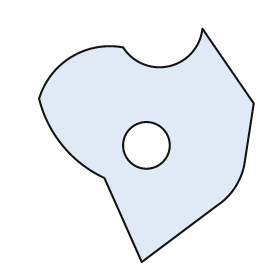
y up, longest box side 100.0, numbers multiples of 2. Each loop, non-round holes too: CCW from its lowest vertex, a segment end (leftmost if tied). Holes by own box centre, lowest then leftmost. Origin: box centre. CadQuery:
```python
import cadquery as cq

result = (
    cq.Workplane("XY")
    .moveTo(-2.0, -50.0)
    .lineTo(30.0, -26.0)
    .threePointArc((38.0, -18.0), (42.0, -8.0))
    .lineTo(46.0, 18.0)
    .lineTo(24.0, 50.0)
    .threePointArc((10.0, 34.0), (-10.0, 42.0))
    .threePointArc((-32.0, 38.0), (-46.0, 20.0))
    .threePointArc((-36.0, 0.0), (-18.0, -14.0))
    .close()
    .moveTo(0.0, 0.0)
    .circle(10.0)
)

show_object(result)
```